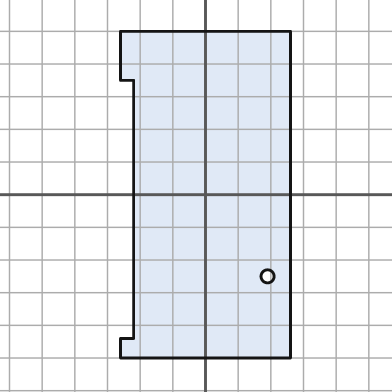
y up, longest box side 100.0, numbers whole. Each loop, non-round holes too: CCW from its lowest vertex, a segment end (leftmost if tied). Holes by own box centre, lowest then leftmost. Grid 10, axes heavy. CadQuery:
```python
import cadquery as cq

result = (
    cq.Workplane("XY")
    .moveTo(-26.0, -50.0)
    .lineTo(26.0, -50.0)
    .lineTo(26.0, 50.0)
    .lineTo(-26.0, 50.0)
    .lineTo(-26.0, 35.0)
    .lineTo(-22.0, 35.0)
    .lineTo(-22.0, -44.0)
    .lineTo(-26.0, -44.0)
    .close()
    .moveTo(19.0, -25.0)
    .circle(2.0)
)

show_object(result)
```